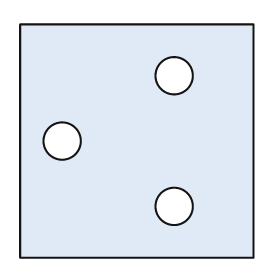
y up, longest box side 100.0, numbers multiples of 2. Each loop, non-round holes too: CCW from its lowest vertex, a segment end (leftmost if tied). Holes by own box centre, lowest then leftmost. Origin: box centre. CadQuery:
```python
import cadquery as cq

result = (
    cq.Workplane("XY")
    .moveTo(-50.0, -50.0)
    .lineTo(50.0, -50.0)
    .lineTo(50.0, 50.0)
    .lineTo(-50.0, 50.0)
    .close()
    .moveTo(16.0, -28.0)
    .circle(8.0)
    .moveTo(-32.0, 0.0)
    .circle(8.0)
    .moveTo(16.0, 28.0)
    .circle(8.0)
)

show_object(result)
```